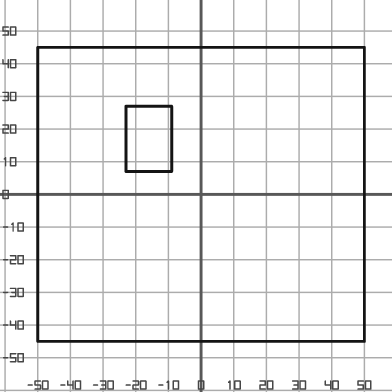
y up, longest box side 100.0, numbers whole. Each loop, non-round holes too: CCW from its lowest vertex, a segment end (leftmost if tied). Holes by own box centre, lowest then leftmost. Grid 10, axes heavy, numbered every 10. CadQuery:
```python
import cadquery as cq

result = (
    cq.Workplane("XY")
    .moveTo(-50.0, -45.0)
    .lineTo(50.0, -45.0)
    .lineTo(50.0, 45.0)
    .lineTo(-50.0, 45.0)
    .close()
    .moveTo(-23.0, 7.0)
    .lineTo(-9.0, 7.0)
    .lineTo(-9.0, 27.0)
    .lineTo(-23.0, 27.0)
    .close()
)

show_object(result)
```